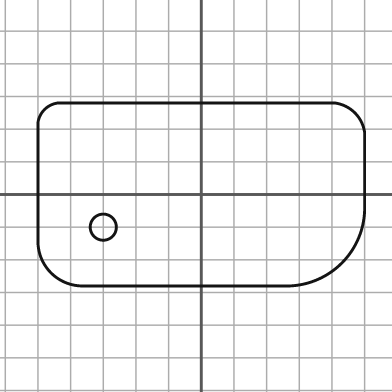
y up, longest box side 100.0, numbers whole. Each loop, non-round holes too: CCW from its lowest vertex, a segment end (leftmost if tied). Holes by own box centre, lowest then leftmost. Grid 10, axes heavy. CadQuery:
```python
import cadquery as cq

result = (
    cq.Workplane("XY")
    .moveTo(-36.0, -28.0)
    .lineTo(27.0, -28.0)
    .threePointArc((43.0, -21.0), (50.0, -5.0))
    .lineTo(50.0, 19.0)
    .threePointArc((47.0, 25.0), (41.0, 28.0))
    .lineTo(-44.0, 28.0)
    .threePointArc((-48.0, 26.0), (-50.0, 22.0))
    .lineTo(-50.0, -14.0)
    .threePointArc((-46.0, -24.0), (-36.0, -28.0))
    .close()
    .moveTo(-30.0, -10.0)
    .circle(4.0)
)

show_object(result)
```